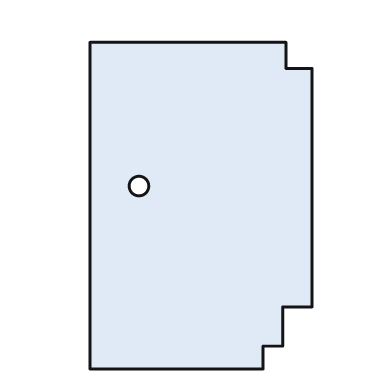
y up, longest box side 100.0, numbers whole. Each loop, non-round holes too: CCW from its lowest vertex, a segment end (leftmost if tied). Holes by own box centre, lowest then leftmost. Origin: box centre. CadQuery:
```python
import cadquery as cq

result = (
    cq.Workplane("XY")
    .moveTo(-34.0, -50.0)
    .lineTo(19.0, -50.0)
    .lineTo(19.0, -43.0)
    .lineTo(25.0, -43.0)
    .lineTo(25.0, -31.0)
    .lineTo(34.0, -31.0)
    .lineTo(34.0, 42.0)
    .lineTo(26.0, 42.0)
    .lineTo(26.0, 50.0)
    .lineTo(-34.0, 50.0)
    .close()
    .moveTo(-19.0, 6.0)
    .circle(3.0)
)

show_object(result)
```